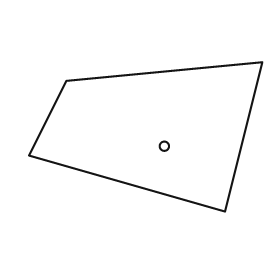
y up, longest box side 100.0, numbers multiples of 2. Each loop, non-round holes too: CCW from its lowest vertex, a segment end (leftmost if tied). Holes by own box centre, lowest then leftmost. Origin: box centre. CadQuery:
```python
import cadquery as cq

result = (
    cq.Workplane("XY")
    .moveTo(34.0, -32.0)
    .lineTo(50.0, 32.0)
    .lineTo(-34.0, 24.0)
    .lineTo(-50.0, -8.0)
    .close()
    .moveTo(8.0, -4.0)
    .circle(2.0)
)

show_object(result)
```